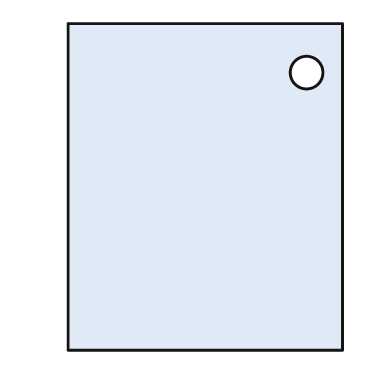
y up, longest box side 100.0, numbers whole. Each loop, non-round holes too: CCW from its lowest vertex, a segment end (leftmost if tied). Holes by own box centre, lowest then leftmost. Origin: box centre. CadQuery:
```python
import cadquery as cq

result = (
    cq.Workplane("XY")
    .moveTo(-42.0, -50.0)
    .lineTo(42.0, -50.0)
    .lineTo(42.0, 50.0)
    .lineTo(-42.0, 50.0)
    .close()
    .moveTo(31.0, 35.0)
    .circle(5.0)
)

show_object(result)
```